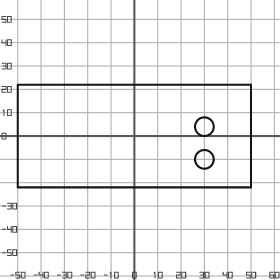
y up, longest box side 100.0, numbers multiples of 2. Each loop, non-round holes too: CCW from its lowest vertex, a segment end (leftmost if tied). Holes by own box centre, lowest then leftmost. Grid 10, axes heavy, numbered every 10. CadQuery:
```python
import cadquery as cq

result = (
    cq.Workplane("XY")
    .moveTo(-50.0, -22.0)
    .lineTo(50.0, -22.0)
    .lineTo(50.0, 22.0)
    .lineTo(-50.0, 22.0)
    .close()
    .moveTo(30.0, -10.0)
    .circle(4.0)
    .moveTo(30.0, 4.0)
    .circle(4.0)
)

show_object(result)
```